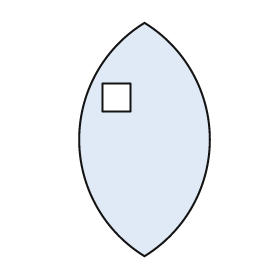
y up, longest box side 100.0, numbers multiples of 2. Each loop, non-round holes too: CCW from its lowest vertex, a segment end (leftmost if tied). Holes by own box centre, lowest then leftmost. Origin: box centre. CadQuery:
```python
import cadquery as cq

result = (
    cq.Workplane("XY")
    .moveTo(0.0, -50.0)
    .threePointArc((28.0, 0.0), (0.0, 50.0))
    .threePointArc((-28.0, 0.0), (0.0, -50.0))
    .close()
    .moveTo(-18.0, 12.0)
    .lineTo(-6.0, 12.0)
    .lineTo(-6.0, 24.0)
    .lineTo(-18.0, 24.0)
    .close()
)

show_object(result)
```